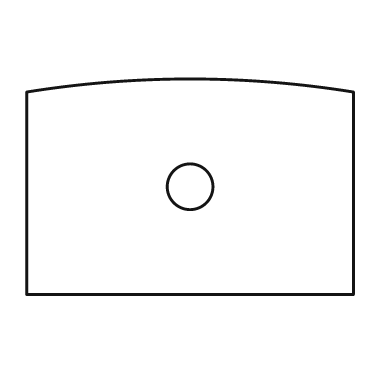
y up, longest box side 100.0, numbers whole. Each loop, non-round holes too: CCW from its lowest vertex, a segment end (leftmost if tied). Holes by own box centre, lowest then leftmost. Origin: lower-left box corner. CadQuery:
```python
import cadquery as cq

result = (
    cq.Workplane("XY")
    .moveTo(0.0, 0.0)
    .lineTo(100.0, 0.0)
    .lineTo(100.0, 62.0)
    .threePointArc((50.0, 66.0), (0.0, 62.0))
    .close()
    .moveTo(50.0, 33.0)
    .circle(7.0)
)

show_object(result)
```